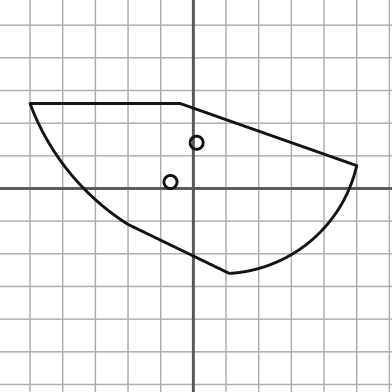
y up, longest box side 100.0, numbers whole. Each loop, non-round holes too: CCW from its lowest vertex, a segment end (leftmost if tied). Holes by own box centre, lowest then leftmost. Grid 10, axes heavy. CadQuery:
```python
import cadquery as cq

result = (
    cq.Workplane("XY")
    .moveTo(11.0, -26.0)
    .threePointArc((36.0, -16.0), (50.0, 7.0))
    .lineTo(-4.0, 26.0)
    .lineTo(-50.0, 26.0)
    .threePointArc((-38.0, 5.0), (-20.0, -11.0))
    .close()
    .moveTo(-7.0, 2.0)
    .circle(2.0)
    .moveTo(1.0, 14.0)
    .circle(2.0)
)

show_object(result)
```